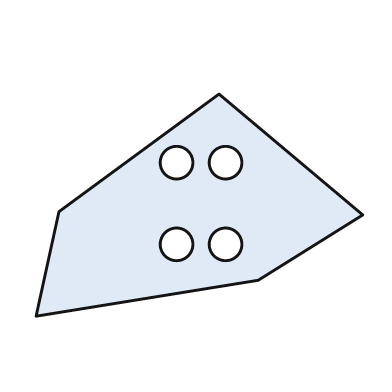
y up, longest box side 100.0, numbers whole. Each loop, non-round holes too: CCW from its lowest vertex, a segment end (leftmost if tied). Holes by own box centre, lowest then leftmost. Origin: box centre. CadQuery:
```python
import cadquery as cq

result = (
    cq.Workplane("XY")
    .moveTo(-50.0, -34.0)
    .lineTo(18.0, -23.0)
    .lineTo(50.0, -3.0)
    .lineTo(6.0, 34.0)
    .lineTo(-43.0, -2.0)
    .close()
    .moveTo(-7.0, -12.0)
    .circle(5.0)
    .moveTo(8.0, -12.0)
    .circle(5.0)
    .moveTo(-7.0, 13.0)
    .circle(5.0)
    .moveTo(8.0, 13.0)
    .circle(5.0)
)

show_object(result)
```